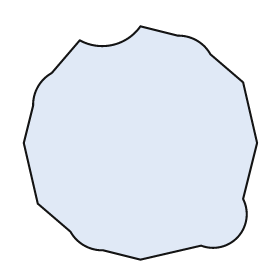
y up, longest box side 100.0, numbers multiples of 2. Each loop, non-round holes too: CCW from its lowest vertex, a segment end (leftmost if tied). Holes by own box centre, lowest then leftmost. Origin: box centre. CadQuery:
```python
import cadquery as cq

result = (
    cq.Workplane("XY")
    .moveTo(0.0, -50.0)
    .lineTo(26.0, -44.0)
    .threePointArc((42.0, -40.0), (44.0, -24.0))
    .lineTo(50.0, 0.0)
    .lineTo(44.0, 26.0)
    .lineTo(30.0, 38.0)
    .threePointArc((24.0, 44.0), (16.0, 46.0))
    .lineTo(0.0, 50.0)
    .threePointArc((-12.0, 42.0), (-26.0, 44.0))
    .lineTo(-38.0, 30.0)
    .threePointArc((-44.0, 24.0), (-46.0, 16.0))
    .lineTo(-50.0, 0.0)
    .lineTo(-44.0, -26.0)
    .lineTo(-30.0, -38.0)
    .threePointArc((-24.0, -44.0), (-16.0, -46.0))
    .close()
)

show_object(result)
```